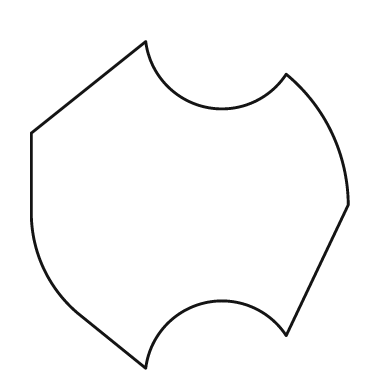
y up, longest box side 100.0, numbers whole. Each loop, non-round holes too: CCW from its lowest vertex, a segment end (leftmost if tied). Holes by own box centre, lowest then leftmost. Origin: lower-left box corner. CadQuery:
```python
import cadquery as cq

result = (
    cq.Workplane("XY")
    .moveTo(35.0, 0.0)
    .threePointArc((53.0, 20.0), (78.0, 10.0))
    .lineTo(97.0, 50.0)
    .threePointArc((92.0, 72.0), (78.0, 90.0))
    .threePointArc((53.0, 80.0), (35.0, 100.0))
    .lineTo(0.0, 72.0)
    .lineTo(0.0, 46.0)
    .threePointArc((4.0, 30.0), (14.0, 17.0))
    .close()
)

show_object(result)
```